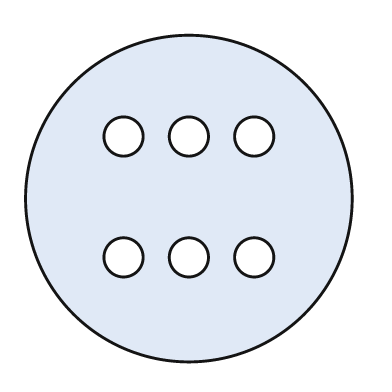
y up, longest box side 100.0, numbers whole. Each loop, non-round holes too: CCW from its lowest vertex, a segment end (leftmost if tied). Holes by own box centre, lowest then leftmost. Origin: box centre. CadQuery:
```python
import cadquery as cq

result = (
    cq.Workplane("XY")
    .moveTo(0.0, 0.0)
    .circle(50.0)
    .moveTo(-20.0, -18.0)
    .circle(6.0)
    .moveTo(0.0, -18.0)
    .circle(6.0)
    .moveTo(20.0, -18.0)
    .circle(6.0)
    .moveTo(-20.0, 19.0)
    .circle(6.0)
    .moveTo(0.0, 19.0)
    .circle(6.0)
    .moveTo(20.0, 19.0)
    .circle(6.0)
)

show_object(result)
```